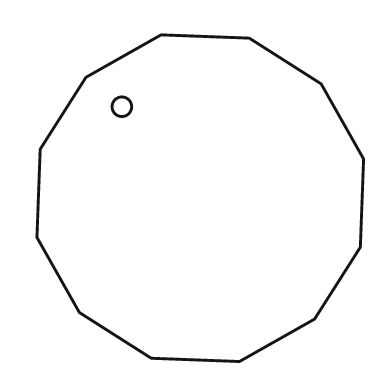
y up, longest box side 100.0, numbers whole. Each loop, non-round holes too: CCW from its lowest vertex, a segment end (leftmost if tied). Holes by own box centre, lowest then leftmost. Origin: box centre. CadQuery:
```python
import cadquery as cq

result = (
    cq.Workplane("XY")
    .moveTo(12.0, -50.0)
    .lineTo(35.0, -37.0)
    .lineTo(49.0, -15.0)
    .lineTo(50.0, 12.0)
    .lineTo(37.0, 35.0)
    .lineTo(15.0, 49.0)
    .lineTo(-12.0, 50.0)
    .lineTo(-35.0, 37.0)
    .lineTo(-49.0, 15.0)
    .lineTo(-50.0, -12.0)
    .lineTo(-37.0, -35.0)
    .lineTo(-15.0, -49.0)
    .close()
    .moveTo(-24.0, 28.0)
    .circle(3.0)
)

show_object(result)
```